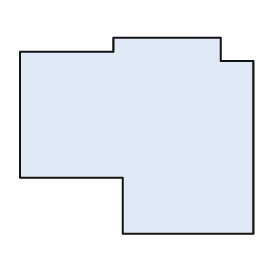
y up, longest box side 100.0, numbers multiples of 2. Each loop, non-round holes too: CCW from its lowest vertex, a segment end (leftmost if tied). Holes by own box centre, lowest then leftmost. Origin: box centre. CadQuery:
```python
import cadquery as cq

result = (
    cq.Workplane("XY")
    .moveTo(-6.0, -42.0)
    .lineTo(50.0, -42.0)
    .lineTo(50.0, 32.0)
    .lineTo(36.0, 32.0)
    .lineTo(36.0, 42.0)
    .lineTo(-10.0, 42.0)
    .lineTo(-10.0, 36.0)
    .lineTo(-50.0, 36.0)
    .lineTo(-50.0, -18.0)
    .lineTo(-6.0, -18.0)
    .close()
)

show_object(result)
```